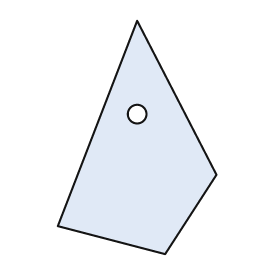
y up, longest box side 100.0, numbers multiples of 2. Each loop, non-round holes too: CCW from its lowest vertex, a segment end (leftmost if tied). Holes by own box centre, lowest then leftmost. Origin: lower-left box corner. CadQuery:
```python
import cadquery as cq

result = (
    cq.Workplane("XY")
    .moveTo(46.0, 0.0)
    .lineTo(68.0, 34.0)
    .lineTo(34.0, 100.0)
    .lineTo(0.0, 12.0)
    .close()
    .moveTo(34.0, 60.0)
    .circle(4.0)
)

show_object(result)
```